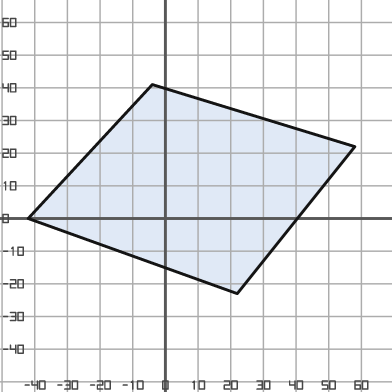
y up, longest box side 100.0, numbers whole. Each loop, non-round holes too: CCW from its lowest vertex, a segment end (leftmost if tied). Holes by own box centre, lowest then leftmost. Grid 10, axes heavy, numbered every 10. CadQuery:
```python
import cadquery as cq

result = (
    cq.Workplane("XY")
    .moveTo(22.0, -23.0)
    .lineTo(58.0, 22.0)
    .lineTo(-4.0, 41.0)
    .lineTo(-42.0, 0.0)
    .close()
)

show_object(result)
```